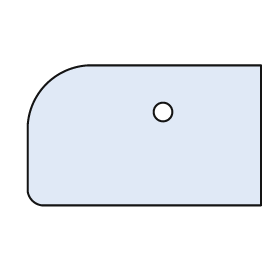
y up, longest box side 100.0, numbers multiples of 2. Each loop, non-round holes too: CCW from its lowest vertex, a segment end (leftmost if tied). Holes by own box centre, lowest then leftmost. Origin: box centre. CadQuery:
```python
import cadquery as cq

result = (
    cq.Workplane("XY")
    .moveTo(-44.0, -30.0)
    .lineTo(50.0, -30.0)
    .lineTo(50.0, 30.0)
    .lineTo(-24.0, 30.0)
    .threePointArc((-42.0, 22.0), (-50.0, 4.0))
    .lineTo(-50.0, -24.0)
    .threePointArc((-48.0, -28.0), (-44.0, -30.0))
    .close()
    .moveTo(8.0, 10.0)
    .circle(4.0)
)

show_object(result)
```